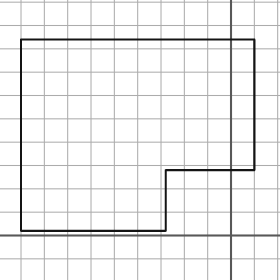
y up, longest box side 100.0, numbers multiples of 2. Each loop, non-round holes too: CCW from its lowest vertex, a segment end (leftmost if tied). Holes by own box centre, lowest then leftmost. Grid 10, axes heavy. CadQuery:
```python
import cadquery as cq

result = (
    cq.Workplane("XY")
    .moveTo(-90.0, 2.0)
    .lineTo(-28.0, 2.0)
    .lineTo(-28.0, 28.0)
    .lineTo(10.0, 28.0)
    .lineTo(10.0, 84.0)
    .lineTo(-90.0, 84.0)
    .close()
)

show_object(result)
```